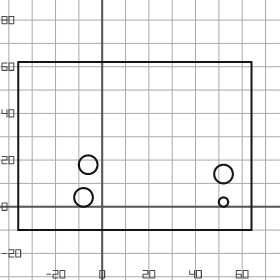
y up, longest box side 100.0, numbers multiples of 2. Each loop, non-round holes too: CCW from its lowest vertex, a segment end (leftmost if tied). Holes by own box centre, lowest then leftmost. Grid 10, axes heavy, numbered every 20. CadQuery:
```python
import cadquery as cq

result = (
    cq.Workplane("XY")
    .moveTo(-36.0, -10.0)
    .lineTo(64.0, -10.0)
    .lineTo(64.0, 62.0)
    .lineTo(-36.0, 62.0)
    .close()
    .moveTo(52.0, 2.0)
    .circle(2.0)
    .moveTo(-8.0, 4.0)
    .circle(4.0)
    .moveTo(52.0, 14.0)
    .circle(4.0)
    .moveTo(-6.0, 18.0)
    .circle(4.0)
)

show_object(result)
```